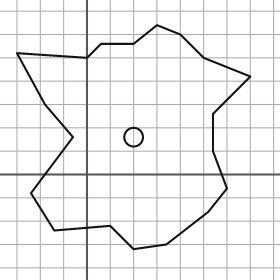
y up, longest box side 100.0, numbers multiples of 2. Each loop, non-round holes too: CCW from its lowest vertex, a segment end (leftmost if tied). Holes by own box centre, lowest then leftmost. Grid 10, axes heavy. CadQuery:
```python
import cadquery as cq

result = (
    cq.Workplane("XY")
    .moveTo(20.0, -32.0)
    .lineTo(34.0, -30.0)
    .lineTo(52.0, -16.0)
    .lineTo(60.0, -6.0)
    .lineTo(54.0, 10.0)
    .lineTo(54.0, 26.0)
    .lineTo(70.0, 42.0)
    .lineTo(50.0, 50.0)
    .lineTo(40.0, 60.0)
    .lineTo(30.0, 64.0)
    .lineTo(20.0, 56.0)
    .lineTo(6.0, 56.0)
    .lineTo(0.0, 50.0)
    .lineTo(-30.0, 52.0)
    .lineTo(-18.0, 30.0)
    .lineTo(-6.0, 16.0)
    .lineTo(-24.0, -8.0)
    .lineTo(-14.0, -24.0)
    .lineTo(10.0, -22.0)
    .close()
    .moveTo(20.0, 16.0)
    .circle(4.0)
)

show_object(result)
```